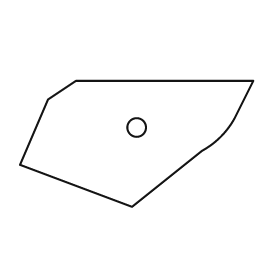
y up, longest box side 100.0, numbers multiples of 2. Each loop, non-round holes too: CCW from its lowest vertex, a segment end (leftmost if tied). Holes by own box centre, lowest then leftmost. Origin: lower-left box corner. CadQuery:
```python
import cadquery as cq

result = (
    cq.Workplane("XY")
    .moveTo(48.0, 0.0)
    .lineTo(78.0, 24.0)
    .threePointArc((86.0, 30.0), (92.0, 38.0))
    .lineTo(100.0, 54.0)
    .lineTo(24.0, 54.0)
    .lineTo(12.0, 46.0)
    .lineTo(0.0, 18.0)
    .close()
    .moveTo(50.0, 34.0)
    .circle(4.0)
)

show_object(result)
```